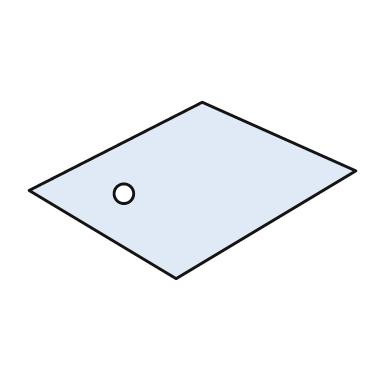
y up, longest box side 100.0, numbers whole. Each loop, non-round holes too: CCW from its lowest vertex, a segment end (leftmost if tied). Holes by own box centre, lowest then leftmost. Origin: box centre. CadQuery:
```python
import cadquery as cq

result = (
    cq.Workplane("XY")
    .moveTo(-5.0, -27.0)
    .lineTo(50.0, 6.0)
    .lineTo(3.0, 27.0)
    .lineTo(-50.0, 0.0)
    .close()
    .moveTo(-21.0, -1.0)
    .circle(3.0)
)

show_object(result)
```